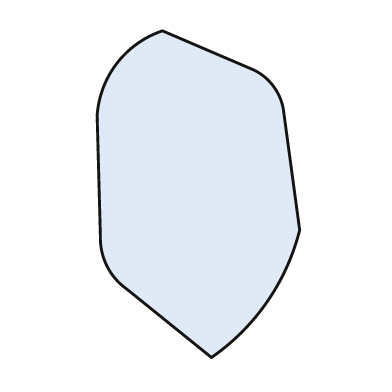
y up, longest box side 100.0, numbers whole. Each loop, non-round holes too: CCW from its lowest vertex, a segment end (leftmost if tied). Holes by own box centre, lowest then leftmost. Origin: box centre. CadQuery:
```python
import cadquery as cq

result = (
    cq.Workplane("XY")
    .moveTo(4.0, -50.0)
    .threePointArc((21.0, -33.0), (31.0, -11.0))
    .lineTo(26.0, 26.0)
    .threePointArc((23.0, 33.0), (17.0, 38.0))
    .lineTo(-11.0, 50.0)
    .threePointArc((-25.0, 40.0), (-31.0, 24.0))
    .lineTo(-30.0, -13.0)
    .threePointArc((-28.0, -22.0), (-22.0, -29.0))
    .close()
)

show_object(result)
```